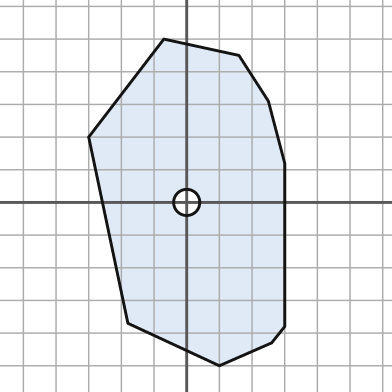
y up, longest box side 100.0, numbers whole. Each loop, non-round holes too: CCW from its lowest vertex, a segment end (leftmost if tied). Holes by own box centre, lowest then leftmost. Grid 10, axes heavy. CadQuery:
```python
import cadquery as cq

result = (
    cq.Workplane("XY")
    .moveTo(10.0, -50.0)
    .lineTo(26.0, -43.0)
    .lineTo(30.0, -38.0)
    .lineTo(30.0, 12.0)
    .lineTo(25.0, 31.0)
    .lineTo(16.0, 45.0)
    .lineTo(-7.0, 50.0)
    .lineTo(-30.0, 20.0)
    .lineTo(-18.0, -37.0)
    .close()
    .moveTo(0.0, 0.0)
    .circle(4.0)
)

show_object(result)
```